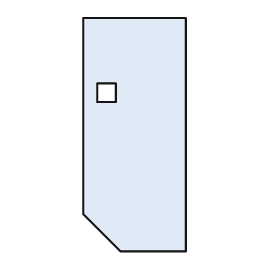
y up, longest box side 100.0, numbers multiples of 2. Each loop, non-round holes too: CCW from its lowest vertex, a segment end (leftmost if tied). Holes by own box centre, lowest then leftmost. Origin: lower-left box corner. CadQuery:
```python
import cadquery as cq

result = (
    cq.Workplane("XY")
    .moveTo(16.0, 0.0)
    .lineTo(44.0, 0.0)
    .lineTo(44.0, 100.0)
    .lineTo(0.0, 100.0)
    .lineTo(0.0, 16.0)
    .close()
    .moveTo(6.0, 64.0)
    .lineTo(14.0, 64.0)
    .lineTo(14.0, 72.0)
    .lineTo(6.0, 72.0)
    .close()
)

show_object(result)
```